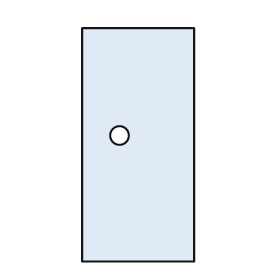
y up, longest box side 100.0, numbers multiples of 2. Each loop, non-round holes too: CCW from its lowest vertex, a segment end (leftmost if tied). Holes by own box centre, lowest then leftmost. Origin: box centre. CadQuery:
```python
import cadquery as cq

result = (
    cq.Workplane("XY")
    .moveTo(-24.0, -50.0)
    .lineTo(24.0, -50.0)
    .lineTo(24.0, 50.0)
    .lineTo(-24.0, 50.0)
    .close()
    .moveTo(-8.0, 4.0)
    .circle(4.0)
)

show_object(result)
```